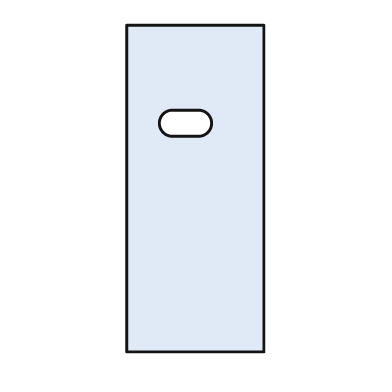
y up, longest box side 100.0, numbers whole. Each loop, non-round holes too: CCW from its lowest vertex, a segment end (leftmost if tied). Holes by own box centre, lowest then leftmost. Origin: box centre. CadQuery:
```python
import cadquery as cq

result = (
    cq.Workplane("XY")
    .moveTo(-21.0, -50.0)
    .lineTo(21.0, -50.0)
    .lineTo(21.0, 50.0)
    .lineTo(-21.0, 50.0)
    .close()
    .moveTo(-7.0, 16.0)
    .lineTo(1.0, 16.0)
    .threePointArc((5.0, 20.0), (1.0, 24.0))
    .lineTo(-7.0, 24.0)
    .threePointArc((-11.0, 20.0), (-7.0, 16.0))
    .close()
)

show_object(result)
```